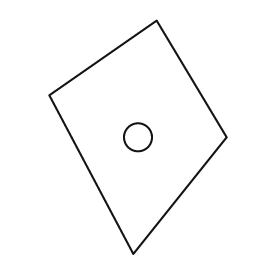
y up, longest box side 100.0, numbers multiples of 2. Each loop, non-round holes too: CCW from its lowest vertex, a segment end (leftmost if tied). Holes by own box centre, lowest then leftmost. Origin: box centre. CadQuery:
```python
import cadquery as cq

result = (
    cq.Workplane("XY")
    .moveTo(-2.0, -50.0)
    .lineTo(38.0, 0.0)
    .lineTo(8.0, 50.0)
    .lineTo(-38.0, 18.0)
    .close()
    .moveTo(0.0, 0.0)
    .circle(6.0)
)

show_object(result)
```